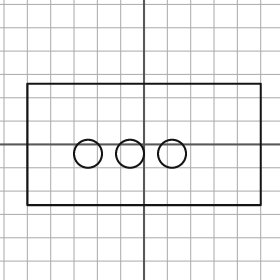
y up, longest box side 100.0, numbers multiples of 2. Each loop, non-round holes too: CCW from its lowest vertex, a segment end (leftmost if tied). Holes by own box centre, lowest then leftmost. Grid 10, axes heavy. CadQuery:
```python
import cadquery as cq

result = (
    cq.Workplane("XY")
    .moveTo(-50.0, -26.0)
    .lineTo(50.0, -26.0)
    .lineTo(50.0, 26.0)
    .lineTo(-50.0, 26.0)
    .close()
    .moveTo(-24.0, -4.0)
    .circle(6.0)
    .moveTo(-6.0, -4.0)
    .circle(6.0)
    .moveTo(12.0, -4.0)
    .circle(6.0)
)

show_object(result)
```